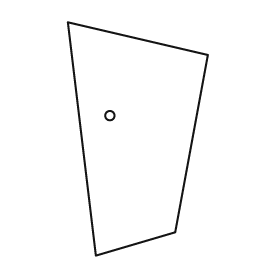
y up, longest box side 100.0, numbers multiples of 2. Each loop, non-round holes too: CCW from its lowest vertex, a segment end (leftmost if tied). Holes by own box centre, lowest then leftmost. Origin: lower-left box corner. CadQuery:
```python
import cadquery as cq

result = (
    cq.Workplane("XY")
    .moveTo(12.0, 0.0)
    .lineTo(46.0, 10.0)
    .lineTo(60.0, 86.0)
    .lineTo(0.0, 100.0)
    .close()
    .moveTo(18.0, 60.0)
    .circle(2.0)
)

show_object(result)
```